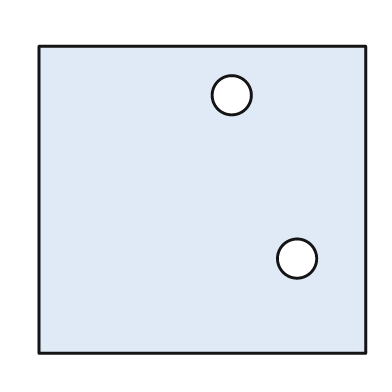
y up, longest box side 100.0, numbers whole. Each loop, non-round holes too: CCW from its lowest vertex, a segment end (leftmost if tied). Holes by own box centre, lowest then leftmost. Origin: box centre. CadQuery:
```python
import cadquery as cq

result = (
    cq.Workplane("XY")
    .moveTo(-50.0, -47.0)
    .lineTo(50.0, -47.0)
    .lineTo(50.0, 47.0)
    .lineTo(-50.0, 47.0)
    .close()
    .moveTo(29.0, -18.0)
    .circle(6.0)
    .moveTo(9.0, 32.0)
    .circle(6.0)
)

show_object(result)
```